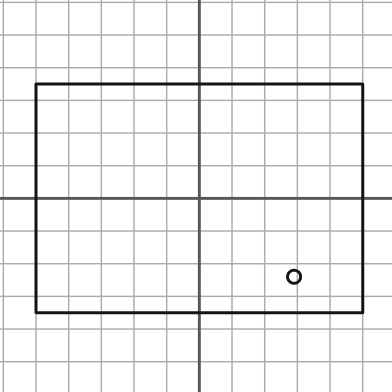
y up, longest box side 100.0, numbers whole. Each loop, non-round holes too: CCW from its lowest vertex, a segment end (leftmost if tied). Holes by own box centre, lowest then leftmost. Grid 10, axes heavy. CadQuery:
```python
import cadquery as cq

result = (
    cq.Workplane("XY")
    .moveTo(-50.0, -35.0)
    .lineTo(50.0, -35.0)
    .lineTo(50.0, 35.0)
    .lineTo(-50.0, 35.0)
    .close()
    .moveTo(29.0, -24.0)
    .circle(2.0)
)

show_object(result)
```